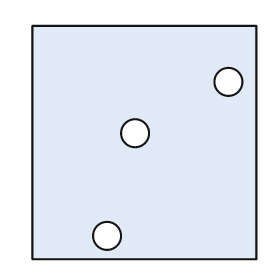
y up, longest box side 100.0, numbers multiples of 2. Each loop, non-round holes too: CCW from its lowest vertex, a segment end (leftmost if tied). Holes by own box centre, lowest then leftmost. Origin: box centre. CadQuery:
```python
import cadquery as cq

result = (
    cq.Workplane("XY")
    .moveTo(-48.0, -50.0)
    .lineTo(48.0, -50.0)
    .lineTo(48.0, 50.0)
    .lineTo(-48.0, 50.0)
    .close()
    .moveTo(-16.0, -40.0)
    .circle(6.0)
    .moveTo(-4.0, 4.0)
    .circle(6.0)
    .moveTo(36.0, 26.0)
    .circle(6.0)
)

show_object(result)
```